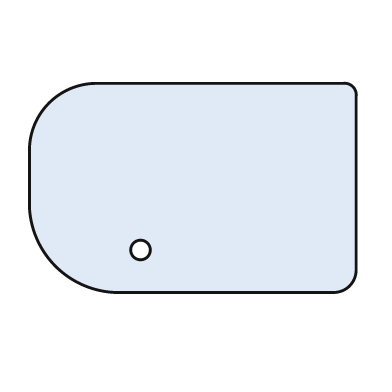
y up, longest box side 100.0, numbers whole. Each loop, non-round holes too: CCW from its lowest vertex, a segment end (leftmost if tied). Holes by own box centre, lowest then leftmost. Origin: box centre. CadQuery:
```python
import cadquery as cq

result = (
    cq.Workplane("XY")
    .moveTo(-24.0, -32.0)
    .lineTo(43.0, -32.0)
    .threePointArc((48.0, -30.0), (50.0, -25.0))
    .lineTo(50.0, 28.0)
    .threePointArc((49.0, 31.0), (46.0, 32.0))
    .lineTo(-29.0, 32.0)
    .threePointArc((-44.0, 26.0), (-50.0, 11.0))
    .lineTo(-50.0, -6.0)
    .threePointArc((-42.0, -24.0), (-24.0, -32.0))
    .close()
    .moveTo(-16.0, -19.0)
    .circle(3.0)
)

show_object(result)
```